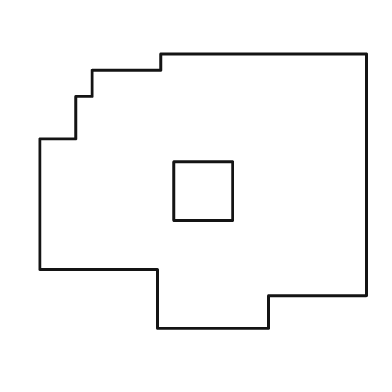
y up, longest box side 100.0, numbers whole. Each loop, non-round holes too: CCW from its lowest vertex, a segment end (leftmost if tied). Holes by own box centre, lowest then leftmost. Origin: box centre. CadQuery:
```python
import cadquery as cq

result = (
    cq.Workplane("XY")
    .moveTo(-14.0, -42.0)
    .lineTo(20.0, -42.0)
    .lineTo(20.0, -32.0)
    .lineTo(50.0, -32.0)
    .lineTo(50.0, 42.0)
    .lineTo(-13.0, 42.0)
    .lineTo(-13.0, 37.0)
    .lineTo(-34.0, 37.0)
    .lineTo(-34.0, 29.0)
    .lineTo(-39.0, 29.0)
    .lineTo(-39.0, 16.0)
    .lineTo(-50.0, 16.0)
    .lineTo(-50.0, -24.0)
    .lineTo(-14.0, -24.0)
    .close()
    .moveTo(-9.0, -9.0)
    .lineTo(9.0, -9.0)
    .lineTo(9.0, 9.0)
    .lineTo(-9.0, 9.0)
    .close()
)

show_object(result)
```